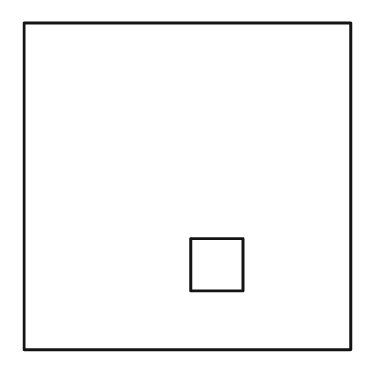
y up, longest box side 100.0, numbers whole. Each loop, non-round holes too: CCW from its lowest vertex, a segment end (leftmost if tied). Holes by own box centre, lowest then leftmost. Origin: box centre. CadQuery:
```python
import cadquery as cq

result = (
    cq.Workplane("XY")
    .moveTo(-50.0, -50.0)
    .lineTo(50.0, -50.0)
    .lineTo(50.0, 50.0)
    .lineTo(-50.0, 50.0)
    .close()
    .moveTo(1.0, -32.0)
    .lineTo(17.0, -32.0)
    .lineTo(17.0, -16.0)
    .lineTo(1.0, -16.0)
    .close()
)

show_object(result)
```